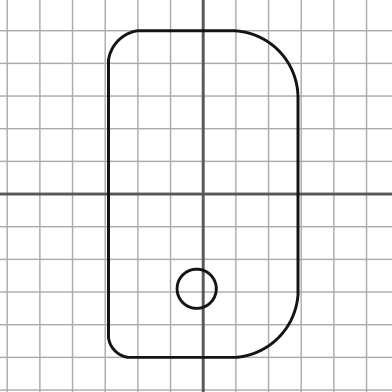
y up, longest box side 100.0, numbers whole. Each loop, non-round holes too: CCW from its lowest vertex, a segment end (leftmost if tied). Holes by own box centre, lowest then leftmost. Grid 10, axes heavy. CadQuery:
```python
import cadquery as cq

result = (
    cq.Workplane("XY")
    .moveTo(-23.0, -50.0)
    .lineTo(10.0, -50.0)
    .threePointArc((23.0, -44.0), (29.0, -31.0))
    .lineTo(29.0, 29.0)
    .threePointArc((23.0, 44.0), (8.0, 50.0))
    .lineTo(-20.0, 50.0)
    .threePointArc((-26.0, 47.0), (-29.0, 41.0))
    .lineTo(-29.0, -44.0)
    .threePointArc((-27.0, -48.0), (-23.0, -50.0))
    .close()
    .moveTo(-2.0, -29.0)
    .circle(6.0)
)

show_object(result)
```